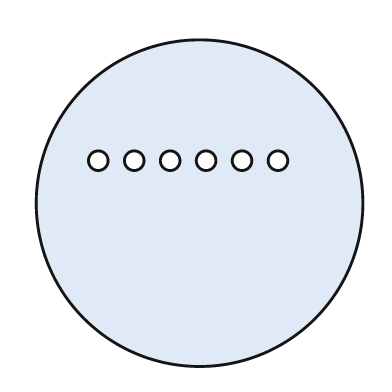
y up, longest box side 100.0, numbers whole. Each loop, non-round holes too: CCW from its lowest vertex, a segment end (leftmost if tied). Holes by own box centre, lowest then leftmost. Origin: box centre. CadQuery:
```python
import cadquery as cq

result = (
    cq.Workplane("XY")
    .moveTo(0.0, 0.0)
    .circle(50.0)
    .moveTo(-31.0, 13.0)
    .circle(3.0)
    .moveTo(-20.0, 13.0)
    .circle(3.0)
    .moveTo(-9.0, 13.0)
    .circle(3.0)
    .moveTo(2.0, 13.0)
    .circle(3.0)
    .moveTo(13.0, 13.0)
    .circle(3.0)
    .moveTo(24.0, 13.0)
    .circle(3.0)
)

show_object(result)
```